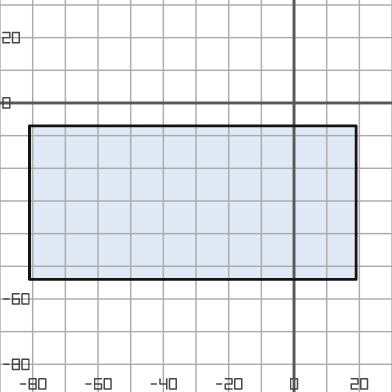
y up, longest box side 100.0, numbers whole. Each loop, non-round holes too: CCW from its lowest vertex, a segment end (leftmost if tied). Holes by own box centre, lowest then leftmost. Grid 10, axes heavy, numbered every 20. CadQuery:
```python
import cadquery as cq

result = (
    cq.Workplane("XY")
    .moveTo(-81.0, -54.0)
    .lineTo(19.0, -54.0)
    .lineTo(19.0, -7.0)
    .lineTo(-81.0, -7.0)
    .close()
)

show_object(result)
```